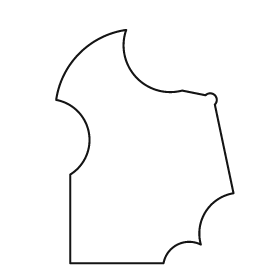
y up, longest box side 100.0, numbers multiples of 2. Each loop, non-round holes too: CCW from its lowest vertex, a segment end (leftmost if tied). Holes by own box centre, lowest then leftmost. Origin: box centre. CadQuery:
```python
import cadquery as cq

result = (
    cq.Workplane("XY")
    .moveTo(-32.0, -50.0)
    .lineTo(8.0, -50.0)
    .threePointArc((14.0, -42.0), (24.0, -42.0))
    .threePointArc((26.0, -28.0), (38.0, -20.0))
    .lineTo(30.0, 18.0)
    .threePointArc((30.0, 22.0), (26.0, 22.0))
    .lineTo(16.0, 24.0)
    .threePointArc((-4.0, 30.0), (-8.0, 50.0))
    .threePointArc((-28.0, 40.0), (-38.0, 20.0))
    .threePointArc((-24.0, 6.0), (-32.0, -12.0))
    .close()
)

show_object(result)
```